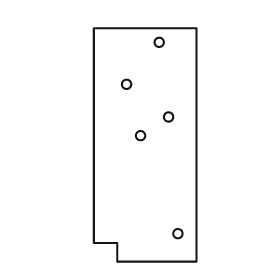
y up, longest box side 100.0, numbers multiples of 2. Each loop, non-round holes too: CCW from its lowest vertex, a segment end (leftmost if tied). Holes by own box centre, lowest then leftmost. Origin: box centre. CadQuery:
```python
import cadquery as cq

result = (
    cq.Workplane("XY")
    .moveTo(-12.0, -50.0)
    .lineTo(22.0, -50.0)
    .lineTo(22.0, 50.0)
    .lineTo(-22.0, 50.0)
    .lineTo(-22.0, -42.0)
    .lineTo(-12.0, -42.0)
    .close()
    .moveTo(14.0, -38.0)
    .circle(2.0)
    .moveTo(-2.0, 4.0)
    .circle(2.0)
    .moveTo(10.0, 12.0)
    .circle(2.0)
    .moveTo(-8.0, 26.0)
    .circle(2.0)
    .moveTo(6.0, 44.0)
    .circle(2.0)
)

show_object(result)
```